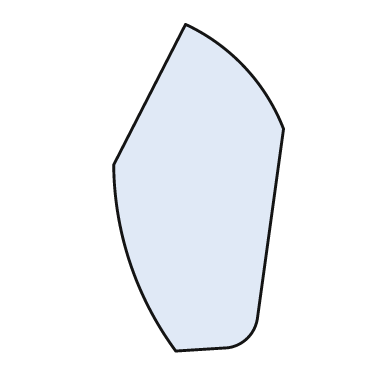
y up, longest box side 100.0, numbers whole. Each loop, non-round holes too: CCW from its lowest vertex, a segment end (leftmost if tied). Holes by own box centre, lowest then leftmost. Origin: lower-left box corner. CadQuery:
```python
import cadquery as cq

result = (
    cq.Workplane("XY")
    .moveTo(19.0, 0.0)
    .lineTo(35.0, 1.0)
    .threePointArc((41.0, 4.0), (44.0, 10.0))
    .lineTo(52.0, 68.0)
    .threePointArc((40.0, 87.0), (22.0, 100.0))
    .lineTo(0.0, 57.0)
    .threePointArc((5.0, 27.0), (19.0, 0.0))
    .close()
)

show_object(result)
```